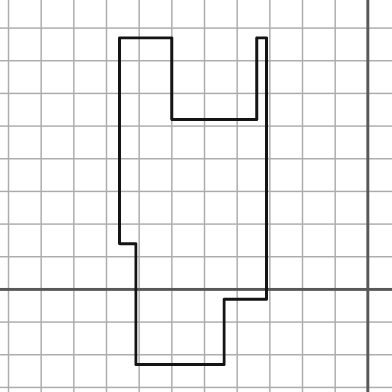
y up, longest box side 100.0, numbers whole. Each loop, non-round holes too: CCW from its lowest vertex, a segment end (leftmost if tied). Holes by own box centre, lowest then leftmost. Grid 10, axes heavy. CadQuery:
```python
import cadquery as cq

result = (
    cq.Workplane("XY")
    .moveTo(-71.0, -23.0)
    .lineTo(-44.0, -23.0)
    .lineTo(-44.0, -3.0)
    .lineTo(-31.0, -3.0)
    .lineTo(-31.0, 77.0)
    .lineTo(-34.0, 77.0)
    .lineTo(-34.0, 52.0)
    .lineTo(-60.0, 52.0)
    .lineTo(-60.0, 77.0)
    .lineTo(-76.0, 77.0)
    .lineTo(-76.0, 14.0)
    .lineTo(-71.0, 14.0)
    .close()
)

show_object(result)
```